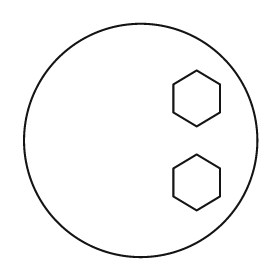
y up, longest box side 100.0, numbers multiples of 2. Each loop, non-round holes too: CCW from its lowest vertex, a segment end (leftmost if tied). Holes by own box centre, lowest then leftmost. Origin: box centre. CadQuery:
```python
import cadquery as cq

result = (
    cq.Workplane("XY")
    .moveTo(0.0, 0.0)
    .circle(50.0)
    .moveTo(24.0, -30.0)
    .lineTo(34.0, -24.0)
    .lineTo(34.0, -12.0)
    .lineTo(24.0, -6.0)
    .lineTo(14.0, -12.0)
    .lineTo(14.0, -24.0)
    .close()
    .moveTo(24.0, 6.0)
    .lineTo(34.0, 12.0)
    .lineTo(34.0, 24.0)
    .lineTo(24.0, 30.0)
    .lineTo(14.0, 24.0)
    .lineTo(14.0, 12.0)
    .close()
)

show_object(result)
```